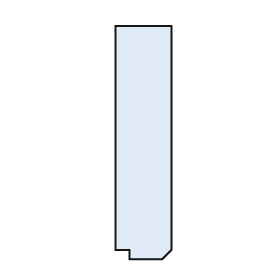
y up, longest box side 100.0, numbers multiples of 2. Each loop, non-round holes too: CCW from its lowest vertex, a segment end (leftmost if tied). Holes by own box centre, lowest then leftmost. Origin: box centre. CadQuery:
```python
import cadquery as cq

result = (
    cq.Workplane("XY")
    .moveTo(-6.0, -50.0)
    .lineTo(8.0, -50.0)
    .lineTo(12.0, -46.0)
    .lineTo(12.0, 50.0)
    .lineTo(-12.0, 50.0)
    .lineTo(-12.0, -46.0)
    .lineTo(-6.0, -46.0)
    .close()
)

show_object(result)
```